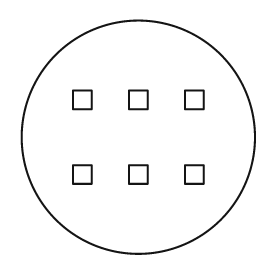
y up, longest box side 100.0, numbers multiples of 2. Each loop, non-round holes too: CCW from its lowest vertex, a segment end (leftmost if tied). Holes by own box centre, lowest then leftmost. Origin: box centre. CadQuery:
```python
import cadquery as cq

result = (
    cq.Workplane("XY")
    .moveTo(0.0, 0.0)
    .circle(50.0)
    .moveTo(-28.0, -20.0)
    .lineTo(-20.0, -20.0)
    .lineTo(-20.0, -12.0)
    .lineTo(-28.0, -12.0)
    .close()
    .moveTo(-4.0, -20.0)
    .lineTo(4.0, -20.0)
    .lineTo(4.0, -12.0)
    .lineTo(-4.0, -12.0)
    .close()
    .moveTo(20.0, -20.0)
    .lineTo(28.0, -20.0)
    .lineTo(28.0, -12.0)
    .lineTo(20.0, -12.0)
    .close()
    .moveTo(-28.0, 12.0)
    .lineTo(-20.0, 12.0)
    .lineTo(-20.0, 20.0)
    .lineTo(-28.0, 20.0)
    .close()
    .moveTo(-4.0, 12.0)
    .lineTo(4.0, 12.0)
    .lineTo(4.0, 20.0)
    .lineTo(-4.0, 20.0)
    .close()
    .moveTo(20.0, 12.0)
    .lineTo(28.0, 12.0)
    .lineTo(28.0, 20.0)
    .lineTo(20.0, 20.0)
    .close()
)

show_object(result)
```